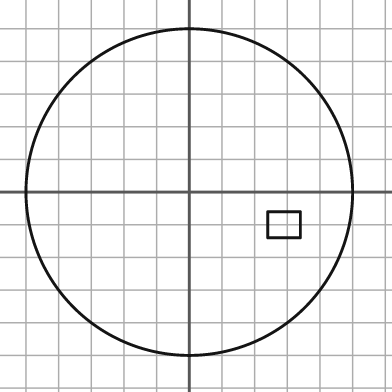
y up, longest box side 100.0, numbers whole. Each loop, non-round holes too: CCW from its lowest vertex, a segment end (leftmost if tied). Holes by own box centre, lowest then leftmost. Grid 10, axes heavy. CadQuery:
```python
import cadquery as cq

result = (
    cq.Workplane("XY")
    .moveTo(0.0, 0.0)
    .circle(50.0)
    .moveTo(24.0, -14.0)
    .lineTo(34.0, -14.0)
    .lineTo(34.0, -6.0)
    .lineTo(24.0, -6.0)
    .close()
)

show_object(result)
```